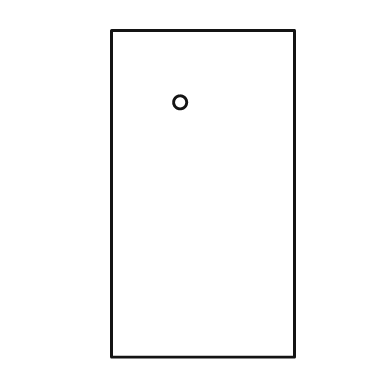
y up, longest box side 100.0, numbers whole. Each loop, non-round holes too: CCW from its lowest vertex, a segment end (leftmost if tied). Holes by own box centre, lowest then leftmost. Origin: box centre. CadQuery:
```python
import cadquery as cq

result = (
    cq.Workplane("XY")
    .moveTo(-28.0, -50.0)
    .lineTo(28.0, -50.0)
    .lineTo(28.0, 50.0)
    .lineTo(-28.0, 50.0)
    .close()
    .moveTo(-7.0, 28.0)
    .circle(2.0)
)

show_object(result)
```